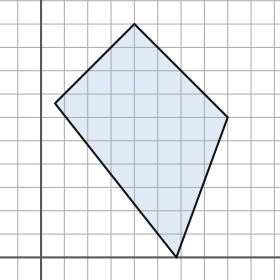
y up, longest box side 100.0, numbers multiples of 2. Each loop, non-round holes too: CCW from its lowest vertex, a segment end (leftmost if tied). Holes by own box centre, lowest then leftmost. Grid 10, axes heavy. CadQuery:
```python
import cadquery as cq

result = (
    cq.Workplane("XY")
    .moveTo(58.0, 0.0)
    .lineTo(80.0, 60.0)
    .lineTo(40.0, 100.0)
    .lineTo(6.0, 66.0)
    .close()
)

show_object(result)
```